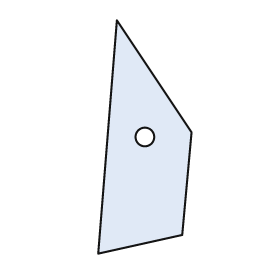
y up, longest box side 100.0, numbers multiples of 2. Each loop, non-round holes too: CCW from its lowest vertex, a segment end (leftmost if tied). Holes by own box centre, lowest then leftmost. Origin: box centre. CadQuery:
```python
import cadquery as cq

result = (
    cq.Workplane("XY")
    .moveTo(-20.0, -50.0)
    .lineTo(16.0, -42.0)
    .lineTo(20.0, 2.0)
    .lineTo(-12.0, 50.0)
    .close()
    .moveTo(0.0, 0.0)
    .circle(4.0)
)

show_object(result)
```